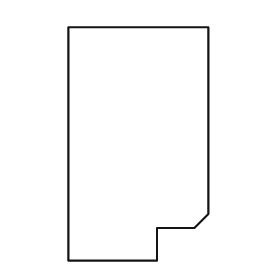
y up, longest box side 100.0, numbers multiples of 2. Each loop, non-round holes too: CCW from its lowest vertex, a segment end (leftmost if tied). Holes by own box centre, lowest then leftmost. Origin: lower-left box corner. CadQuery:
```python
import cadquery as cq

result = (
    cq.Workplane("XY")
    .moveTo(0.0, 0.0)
    .lineTo(38.0, 0.0)
    .lineTo(38.0, 14.0)
    .lineTo(54.0, 14.0)
    .lineTo(60.0, 20.0)
    .lineTo(60.0, 100.0)
    .lineTo(0.0, 100.0)
    .close()
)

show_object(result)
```